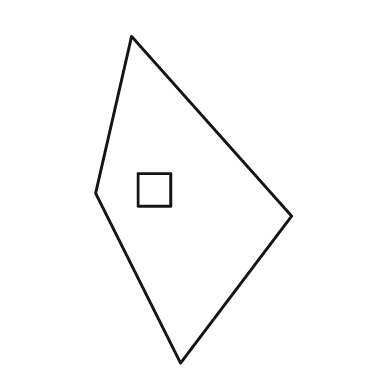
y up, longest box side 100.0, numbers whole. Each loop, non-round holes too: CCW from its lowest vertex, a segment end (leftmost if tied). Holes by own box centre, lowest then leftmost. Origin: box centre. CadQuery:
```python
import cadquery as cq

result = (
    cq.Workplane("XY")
    .moveTo(-4.0, -50.0)
    .lineTo(30.0, -5.0)
    .lineTo(-19.0, 50.0)
    .lineTo(-30.0, 2.0)
    .close()
    .moveTo(-17.0, -2.0)
    .lineTo(-7.0, -2.0)
    .lineTo(-7.0, 8.0)
    .lineTo(-17.0, 8.0)
    .close()
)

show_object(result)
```